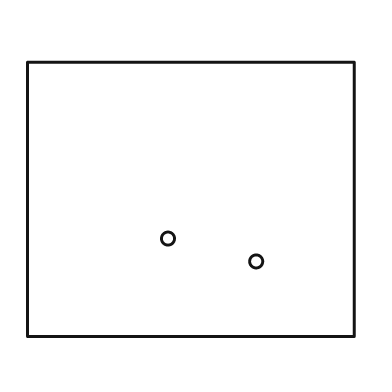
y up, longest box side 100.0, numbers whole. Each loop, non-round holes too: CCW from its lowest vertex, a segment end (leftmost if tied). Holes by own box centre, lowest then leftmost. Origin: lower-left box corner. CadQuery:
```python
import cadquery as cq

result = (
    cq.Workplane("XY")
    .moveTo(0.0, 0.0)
    .lineTo(100.0, 0.0)
    .lineTo(100.0, 84.0)
    .lineTo(0.0, 84.0)
    .close()
    .moveTo(70.0, 23.0)
    .circle(2.0)
    .moveTo(43.0, 30.0)
    .circle(2.0)
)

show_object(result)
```